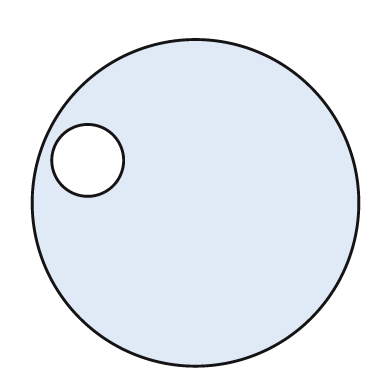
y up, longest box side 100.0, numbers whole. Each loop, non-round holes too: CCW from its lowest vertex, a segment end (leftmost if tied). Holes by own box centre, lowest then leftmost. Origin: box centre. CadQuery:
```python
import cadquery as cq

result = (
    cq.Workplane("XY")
    .moveTo(0.0, 0.0)
    .circle(50.0)
    .moveTo(-33.0, 13.0)
    .circle(11.0)
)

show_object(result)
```